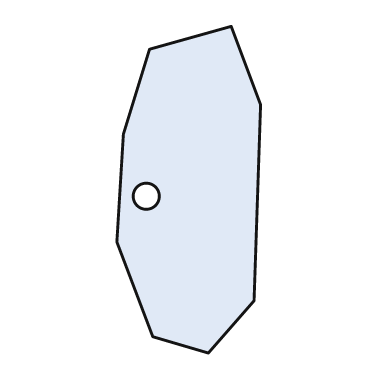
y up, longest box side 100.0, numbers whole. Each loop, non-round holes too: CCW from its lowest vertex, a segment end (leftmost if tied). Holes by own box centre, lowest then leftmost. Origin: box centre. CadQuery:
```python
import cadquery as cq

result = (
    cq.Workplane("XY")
    .moveTo(6.0, -50.0)
    .lineTo(20.0, -34.0)
    .lineTo(22.0, 26.0)
    .lineTo(13.0, 50.0)
    .lineTo(-12.0, 43.0)
    .lineTo(-20.0, 17.0)
    .lineTo(-22.0, -16.0)
    .lineTo(-11.0, -45.0)
    .close()
    .moveTo(-13.0, -2.0)
    .circle(4.0)
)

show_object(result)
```